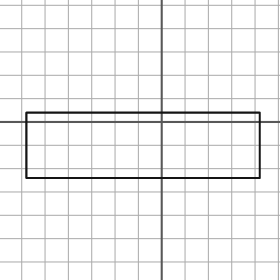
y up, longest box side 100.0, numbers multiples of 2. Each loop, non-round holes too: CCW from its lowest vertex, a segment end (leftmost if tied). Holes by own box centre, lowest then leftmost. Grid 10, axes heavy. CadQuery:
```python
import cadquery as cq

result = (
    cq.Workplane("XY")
    .moveTo(-58.0, -24.0)
    .lineTo(42.0, -24.0)
    .lineTo(42.0, 4.0)
    .lineTo(-58.0, 4.0)
    .close()
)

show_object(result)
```